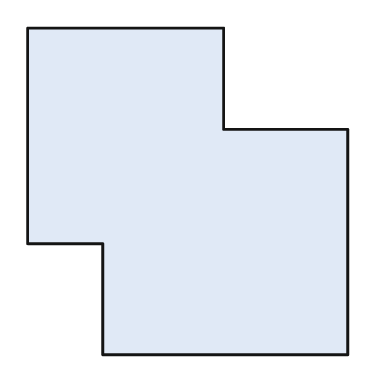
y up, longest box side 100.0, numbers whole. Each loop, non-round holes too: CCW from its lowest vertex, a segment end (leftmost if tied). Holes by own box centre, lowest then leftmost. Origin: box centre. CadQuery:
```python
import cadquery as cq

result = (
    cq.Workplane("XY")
    .moveTo(-26.0, -50.0)
    .lineTo(49.0, -50.0)
    .lineTo(49.0, 19.0)
    .lineTo(11.0, 19.0)
    .lineTo(11.0, 50.0)
    .lineTo(-49.0, 50.0)
    .lineTo(-49.0, -16.0)
    .lineTo(-26.0, -16.0)
    .close()
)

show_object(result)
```